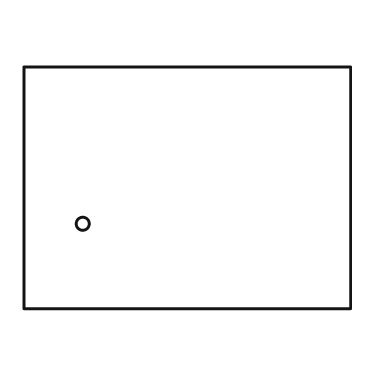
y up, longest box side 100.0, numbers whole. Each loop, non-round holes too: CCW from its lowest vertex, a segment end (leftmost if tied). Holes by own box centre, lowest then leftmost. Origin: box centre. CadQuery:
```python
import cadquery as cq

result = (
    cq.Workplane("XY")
    .moveTo(-50.0, -37.0)
    .lineTo(50.0, -37.0)
    .lineTo(50.0, 37.0)
    .lineTo(-50.0, 37.0)
    .close()
    .moveTo(-32.0, -11.0)
    .circle(2.0)
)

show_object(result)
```